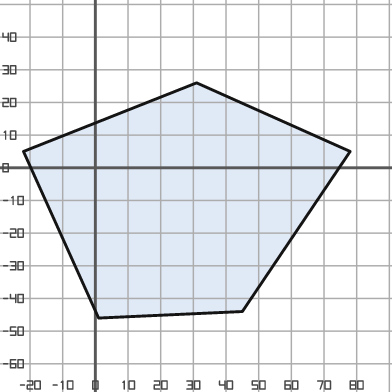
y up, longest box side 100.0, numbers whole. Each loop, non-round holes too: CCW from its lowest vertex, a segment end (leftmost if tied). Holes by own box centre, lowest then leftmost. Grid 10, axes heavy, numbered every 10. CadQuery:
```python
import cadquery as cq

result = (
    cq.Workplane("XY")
    .moveTo(1.0, -46.0)
    .lineTo(45.0, -44.0)
    .lineTo(78.0, 5.0)
    .lineTo(31.0, 26.0)
    .lineTo(-22.0, 5.0)
    .close()
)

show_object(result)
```